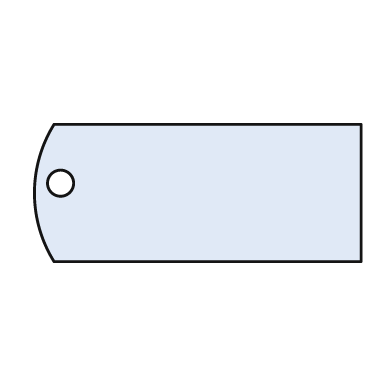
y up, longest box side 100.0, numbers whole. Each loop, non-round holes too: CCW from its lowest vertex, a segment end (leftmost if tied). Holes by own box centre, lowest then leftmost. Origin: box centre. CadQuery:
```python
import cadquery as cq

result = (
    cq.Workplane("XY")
    .moveTo(-44.0, -21.0)
    .lineTo(50.0, -21.0)
    .lineTo(50.0, 21.0)
    .lineTo(-44.0, 21.0)
    .threePointArc((-50.0, 0.0), (-44.0, -21.0))
    .close()
    .moveTo(-42.0, 3.0)
    .circle(4.0)
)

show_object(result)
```